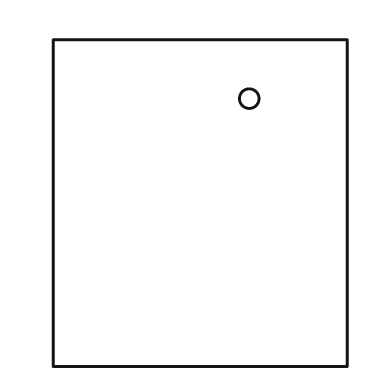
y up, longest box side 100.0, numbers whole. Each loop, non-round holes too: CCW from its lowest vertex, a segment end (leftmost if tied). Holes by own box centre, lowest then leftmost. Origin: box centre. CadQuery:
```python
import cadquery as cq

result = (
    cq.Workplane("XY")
    .moveTo(-45.0, -50.0)
    .lineTo(45.0, -50.0)
    .lineTo(45.0, 50.0)
    .lineTo(-45.0, 50.0)
    .close()
    .moveTo(15.0, 32.0)
    .circle(3.0)
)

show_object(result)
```